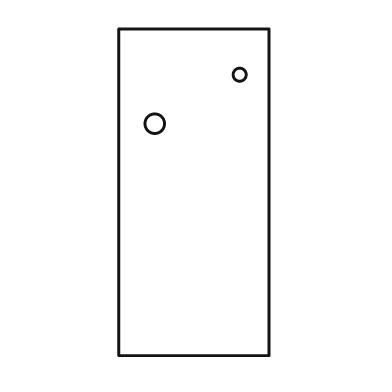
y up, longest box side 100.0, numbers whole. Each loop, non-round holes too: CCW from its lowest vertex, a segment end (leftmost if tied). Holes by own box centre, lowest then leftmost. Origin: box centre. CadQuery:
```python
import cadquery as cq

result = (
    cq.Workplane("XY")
    .moveTo(-23.0, -50.0)
    .lineTo(23.0, -50.0)
    .lineTo(23.0, 50.0)
    .lineTo(-23.0, 50.0)
    .close()
    .moveTo(-12.0, 21.0)
    .circle(3.0)
    .moveTo(14.0, 36.0)
    .circle(2.0)
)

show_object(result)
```